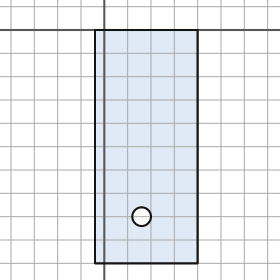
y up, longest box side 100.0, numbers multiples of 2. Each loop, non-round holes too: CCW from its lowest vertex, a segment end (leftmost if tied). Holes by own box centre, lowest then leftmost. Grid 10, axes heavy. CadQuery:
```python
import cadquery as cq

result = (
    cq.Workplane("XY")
    .moveTo(-4.0, -100.0)
    .lineTo(40.0, -100.0)
    .lineTo(40.0, 0.0)
    .lineTo(-4.0, 0.0)
    .close()
    .moveTo(16.0, -80.0)
    .circle(4.0)
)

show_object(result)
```